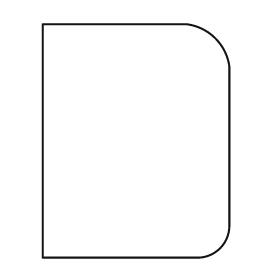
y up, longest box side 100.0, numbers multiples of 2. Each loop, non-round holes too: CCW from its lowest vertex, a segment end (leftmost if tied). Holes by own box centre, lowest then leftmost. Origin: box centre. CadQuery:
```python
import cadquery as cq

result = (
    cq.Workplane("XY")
    .moveTo(-40.0, -50.0)
    .lineTo(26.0, -50.0)
    .threePointArc((36.0, -46.0), (40.0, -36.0))
    .lineTo(40.0, 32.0)
    .threePointArc((34.0, 44.0), (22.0, 50.0))
    .lineTo(-40.0, 50.0)
    .close()
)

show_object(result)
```